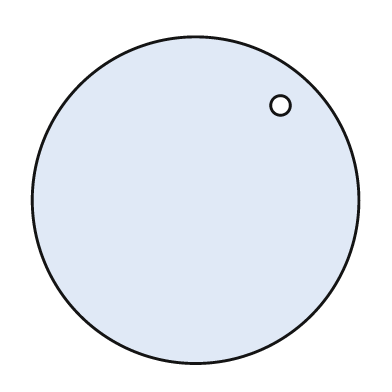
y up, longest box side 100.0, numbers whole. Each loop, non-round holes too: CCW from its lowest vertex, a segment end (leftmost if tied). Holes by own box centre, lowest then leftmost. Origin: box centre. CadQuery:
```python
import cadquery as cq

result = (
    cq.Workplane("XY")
    .moveTo(0.0, 0.0)
    .circle(50.0)
    .moveTo(26.0, 29.0)
    .circle(3.0)
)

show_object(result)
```